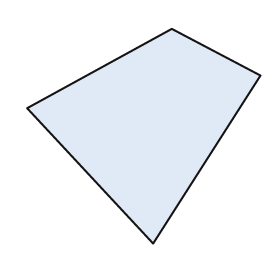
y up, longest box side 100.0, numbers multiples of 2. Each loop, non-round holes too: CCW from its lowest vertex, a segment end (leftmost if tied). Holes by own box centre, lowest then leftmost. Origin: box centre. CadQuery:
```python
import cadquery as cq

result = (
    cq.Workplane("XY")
    .moveTo(4.0, -46.0)
    .lineTo(50.0, 26.0)
    .lineTo(12.0, 46.0)
    .lineTo(-50.0, 12.0)
    .close()
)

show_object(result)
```